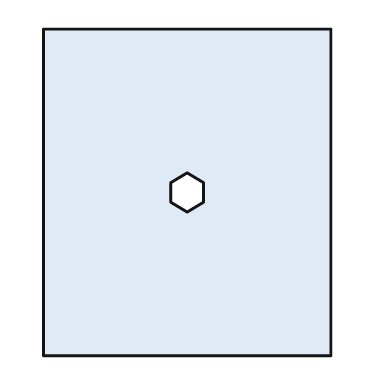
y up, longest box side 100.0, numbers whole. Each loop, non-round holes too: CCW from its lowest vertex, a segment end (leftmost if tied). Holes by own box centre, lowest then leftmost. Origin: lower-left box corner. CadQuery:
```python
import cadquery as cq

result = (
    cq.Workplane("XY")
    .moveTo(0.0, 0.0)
    .lineTo(88.0, 0.0)
    .lineTo(88.0, 100.0)
    .lineTo(0.0, 100.0)
    .close()
    .moveTo(44.0, 44.0)
    .lineTo(49.0, 47.0)
    .lineTo(49.0, 53.0)
    .lineTo(44.0, 56.0)
    .lineTo(39.0, 53.0)
    .lineTo(39.0, 47.0)
    .close()
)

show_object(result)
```